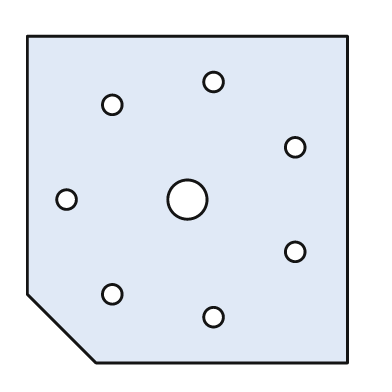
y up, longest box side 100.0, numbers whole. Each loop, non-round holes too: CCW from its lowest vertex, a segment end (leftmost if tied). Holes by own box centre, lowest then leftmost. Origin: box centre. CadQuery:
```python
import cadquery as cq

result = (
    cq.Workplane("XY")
    .moveTo(-28.0, -50.0)
    .lineTo(49.0, -50.0)
    .lineTo(49.0, 50.0)
    .lineTo(-49.0, 50.0)
    .lineTo(-49.0, -29.0)
    .close()
    .moveTo(8.0, -36.0)
    .circle(3.0)
    .moveTo(-23.0, -29.0)
    .circle(3.0)
    .moveTo(33.0, -16.0)
    .circle(3.0)
    .moveTo(-37.0, 0.0)
    .circle(3.0)
    .moveTo(0.0, 0.0)
    .circle(6.0)
    .moveTo(33.0, 16.0)
    .circle(3.0)
    .moveTo(-23.0, 29.0)
    .circle(3.0)
    .moveTo(8.0, 36.0)
    .circle(3.0)
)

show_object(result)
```